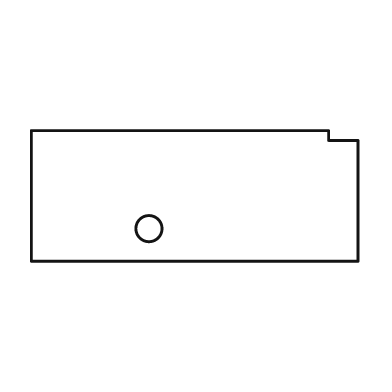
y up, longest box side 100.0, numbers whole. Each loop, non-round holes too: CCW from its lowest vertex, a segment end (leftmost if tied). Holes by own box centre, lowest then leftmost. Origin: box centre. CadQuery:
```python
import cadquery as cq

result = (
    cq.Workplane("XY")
    .moveTo(-50.0, -20.0)
    .lineTo(50.0, -20.0)
    .lineTo(50.0, 17.0)
    .lineTo(41.0, 17.0)
    .lineTo(41.0, 20.0)
    .lineTo(-50.0, 20.0)
    .close()
    .moveTo(-14.0, -10.0)
    .circle(4.0)
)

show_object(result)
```